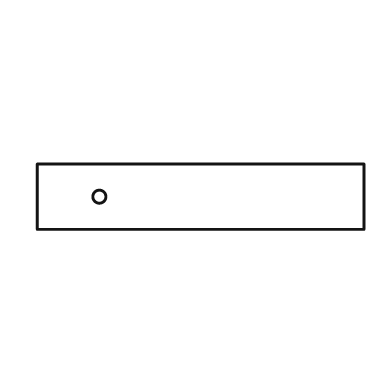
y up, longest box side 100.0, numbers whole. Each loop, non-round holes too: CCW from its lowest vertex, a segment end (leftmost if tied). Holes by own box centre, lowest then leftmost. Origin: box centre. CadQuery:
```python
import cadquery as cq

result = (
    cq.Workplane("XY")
    .moveTo(-50.0, -10.0)
    .lineTo(50.0, -10.0)
    .lineTo(50.0, 10.0)
    .lineTo(-50.0, 10.0)
    .close()
    .moveTo(-31.0, 0.0)
    .circle(2.0)
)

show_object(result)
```